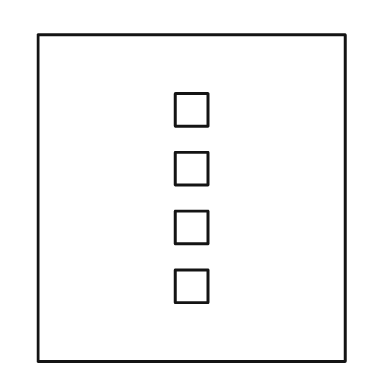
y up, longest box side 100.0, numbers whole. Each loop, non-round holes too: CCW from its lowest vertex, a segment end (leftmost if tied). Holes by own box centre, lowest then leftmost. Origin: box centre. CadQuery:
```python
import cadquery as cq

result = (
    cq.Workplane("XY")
    .moveTo(-47.0, -50.0)
    .lineTo(47.0, -50.0)
    .lineTo(47.0, 50.0)
    .lineTo(-47.0, 50.0)
    .close()
    .moveTo(-5.0, -32.0)
    .lineTo(5.0, -32.0)
    .lineTo(5.0, -22.0)
    .lineTo(-5.0, -22.0)
    .close()
    .moveTo(-5.0, -14.0)
    .lineTo(5.0, -14.0)
    .lineTo(5.0, -4.0)
    .lineTo(-5.0, -4.0)
    .close()
    .moveTo(-5.0, 4.0)
    .lineTo(5.0, 4.0)
    .lineTo(5.0, 14.0)
    .lineTo(-5.0, 14.0)
    .close()
    .moveTo(-5.0, 22.0)
    .lineTo(5.0, 22.0)
    .lineTo(5.0, 32.0)
    .lineTo(-5.0, 32.0)
    .close()
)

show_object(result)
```